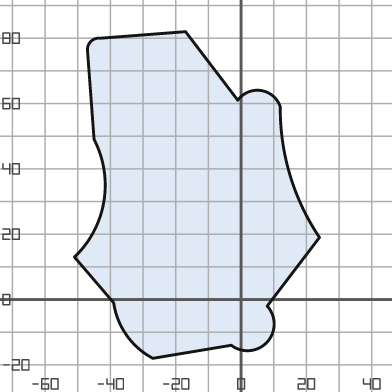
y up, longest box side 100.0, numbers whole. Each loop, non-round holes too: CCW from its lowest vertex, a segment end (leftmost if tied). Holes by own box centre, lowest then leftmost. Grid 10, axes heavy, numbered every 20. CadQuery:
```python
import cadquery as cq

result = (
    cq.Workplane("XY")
    .moveTo(-27.0, -18.0)
    .lineTo(-3.0, -14.0)
    .threePointArc((8.0, -13.0), (8.0, -2.0))
    .lineTo(24.0, 19.0)
    .threePointArc((15.0, 38.0), (12.0, 59.0))
    .threePointArc((6.0, 64.0), (-1.0, 61.0))
    .lineTo(-17.0, 82.0)
    .lineTo(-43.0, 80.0)
    .threePointArc((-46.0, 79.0), (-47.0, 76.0))
    .lineTo(-45.0, 49.0)
    .threePointArc((-42.0, 30.0), (-51.0, 13.0))
    .lineTo(-39.0, -1.0)
    .threePointArc((-35.0, -11.0), (-27.0, -18.0))
    .close()
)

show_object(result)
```